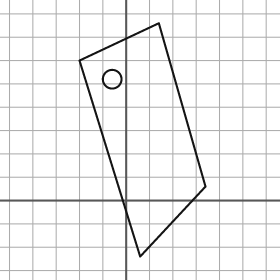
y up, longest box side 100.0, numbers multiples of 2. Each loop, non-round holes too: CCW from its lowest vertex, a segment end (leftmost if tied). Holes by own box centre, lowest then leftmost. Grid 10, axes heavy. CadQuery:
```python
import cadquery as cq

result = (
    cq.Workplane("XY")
    .moveTo(6.0, -24.0)
    .lineTo(34.0, 6.0)
    .lineTo(14.0, 76.0)
    .lineTo(-20.0, 60.0)
    .close()
    .moveTo(-6.0, 52.0)
    .circle(4.0)
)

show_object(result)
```